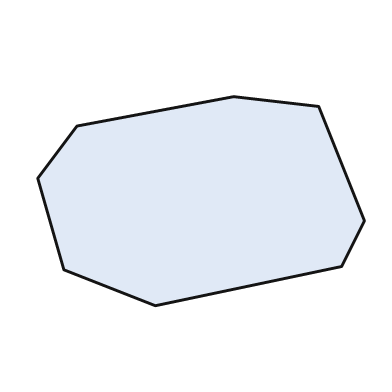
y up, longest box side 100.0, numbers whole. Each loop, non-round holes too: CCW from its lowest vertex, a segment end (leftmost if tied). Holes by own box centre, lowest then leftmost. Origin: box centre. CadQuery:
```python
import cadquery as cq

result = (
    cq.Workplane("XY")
    .moveTo(-14.0, -32.0)
    .lineTo(43.0, -20.0)
    .lineTo(50.0, -6.0)
    .lineTo(36.0, 29.0)
    .lineTo(10.0, 32.0)
    .lineTo(-38.0, 23.0)
    .lineTo(-50.0, 7.0)
    .lineTo(-42.0, -21.0)
    .close()
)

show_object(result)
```